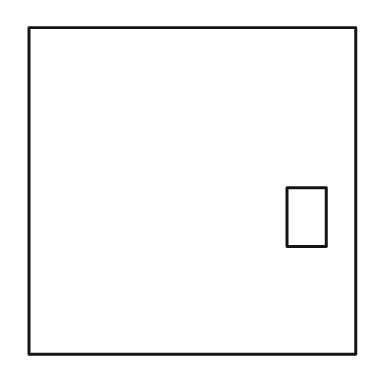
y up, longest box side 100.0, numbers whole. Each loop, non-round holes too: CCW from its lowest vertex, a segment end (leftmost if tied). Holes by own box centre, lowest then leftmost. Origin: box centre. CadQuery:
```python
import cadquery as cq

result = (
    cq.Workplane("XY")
    .moveTo(-50.0, -50.0)
    .lineTo(50.0, -50.0)
    .lineTo(50.0, 50.0)
    .lineTo(-50.0, 50.0)
    .close()
    .moveTo(29.0, -17.0)
    .lineTo(41.0, -17.0)
    .lineTo(41.0, 1.0)
    .lineTo(29.0, 1.0)
    .close()
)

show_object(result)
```